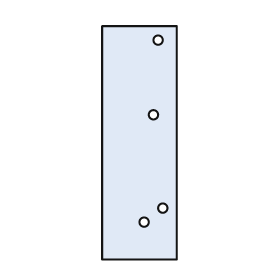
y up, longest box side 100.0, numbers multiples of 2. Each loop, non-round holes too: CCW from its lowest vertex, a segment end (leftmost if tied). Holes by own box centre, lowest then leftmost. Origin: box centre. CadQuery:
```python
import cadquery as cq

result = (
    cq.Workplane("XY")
    .moveTo(-16.0, -50.0)
    .lineTo(16.0, -50.0)
    .lineTo(16.0, 50.0)
    .lineTo(-16.0, 50.0)
    .close()
    .moveTo(2.0, -34.0)
    .circle(2.0)
    .moveTo(10.0, -28.0)
    .circle(2.0)
    .moveTo(6.0, 12.0)
    .circle(2.0)
    .moveTo(8.0, 44.0)
    .circle(2.0)
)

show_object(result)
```